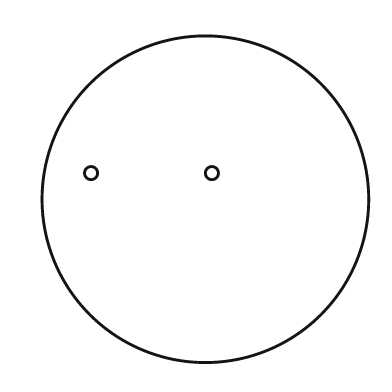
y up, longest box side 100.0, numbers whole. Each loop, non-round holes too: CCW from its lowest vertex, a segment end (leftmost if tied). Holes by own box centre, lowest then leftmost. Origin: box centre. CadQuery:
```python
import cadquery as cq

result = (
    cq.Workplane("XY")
    .moveTo(0.0, 0.0)
    .circle(50.0)
    .moveTo(-35.0, 8.0)
    .circle(2.0)
    .moveTo(2.0, 8.0)
    .circle(2.0)
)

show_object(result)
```